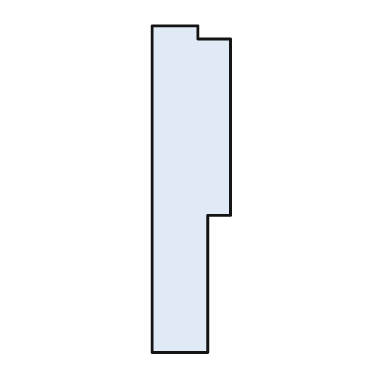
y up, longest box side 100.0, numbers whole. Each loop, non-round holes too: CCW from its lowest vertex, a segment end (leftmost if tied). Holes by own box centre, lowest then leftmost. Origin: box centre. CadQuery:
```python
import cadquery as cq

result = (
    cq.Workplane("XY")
    .moveTo(-12.0, -50.0)
    .lineTo(5.0, -50.0)
    .lineTo(5.0, -8.0)
    .lineTo(12.0, -8.0)
    .lineTo(12.0, 46.0)
    .lineTo(2.0, 46.0)
    .lineTo(2.0, 50.0)
    .lineTo(-12.0, 50.0)
    .close()
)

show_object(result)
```